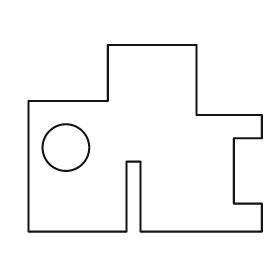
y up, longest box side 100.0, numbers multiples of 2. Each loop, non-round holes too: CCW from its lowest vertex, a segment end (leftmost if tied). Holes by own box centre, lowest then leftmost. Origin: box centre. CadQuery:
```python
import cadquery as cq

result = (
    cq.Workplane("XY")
    .moveTo(-50.0, -40.0)
    .lineTo(-8.0, -40.0)
    .lineTo(-8.0, -10.0)
    .lineTo(-2.0, -10.0)
    .lineTo(-2.0, -40.0)
    .lineTo(50.0, -40.0)
    .lineTo(50.0, -28.0)
    .lineTo(38.0, -28.0)
    .lineTo(38.0, 0.0)
    .lineTo(50.0, 0.0)
    .lineTo(50.0, 10.0)
    .lineTo(22.0, 10.0)
    .lineTo(22.0, 40.0)
    .lineTo(-16.0, 40.0)
    .lineTo(-16.0, 16.0)
    .lineTo(-50.0, 16.0)
    .close()
    .moveTo(-34.0, -4.0)
    .circle(10.0)
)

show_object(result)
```